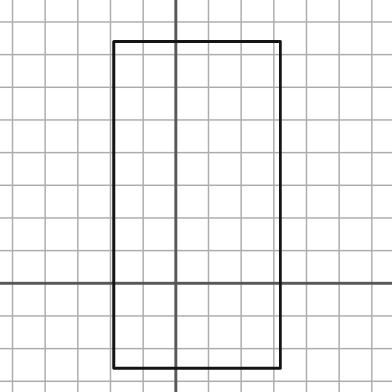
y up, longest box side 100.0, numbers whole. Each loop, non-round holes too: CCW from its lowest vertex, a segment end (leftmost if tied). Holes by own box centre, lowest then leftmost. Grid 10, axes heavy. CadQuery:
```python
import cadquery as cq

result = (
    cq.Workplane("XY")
    .moveTo(-19.0, -26.0)
    .lineTo(32.0, -26.0)
    .lineTo(32.0, 74.0)
    .lineTo(-19.0, 74.0)
    .close()
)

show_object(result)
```